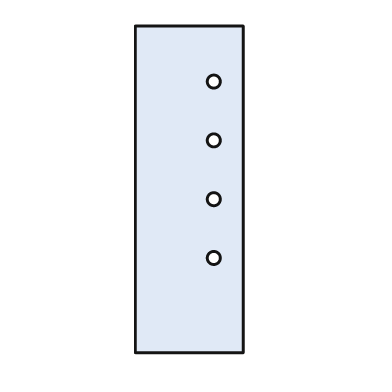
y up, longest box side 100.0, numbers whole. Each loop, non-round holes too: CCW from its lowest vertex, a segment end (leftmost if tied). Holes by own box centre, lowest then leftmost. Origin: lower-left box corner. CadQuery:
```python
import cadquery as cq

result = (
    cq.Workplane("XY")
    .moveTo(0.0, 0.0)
    .lineTo(33.0, 0.0)
    .lineTo(33.0, 100.0)
    .lineTo(0.0, 100.0)
    .close()
    .moveTo(24.0, 29.0)
    .circle(2.0)
    .moveTo(24.0, 47.0)
    .circle(2.0)
    .moveTo(24.0, 65.0)
    .circle(2.0)
    .moveTo(24.0, 83.0)
    .circle(2.0)
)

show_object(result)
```